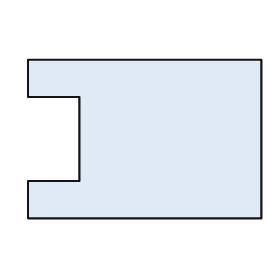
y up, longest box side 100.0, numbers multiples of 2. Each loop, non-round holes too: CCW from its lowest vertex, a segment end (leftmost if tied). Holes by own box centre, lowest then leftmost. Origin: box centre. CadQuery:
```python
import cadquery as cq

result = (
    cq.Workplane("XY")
    .moveTo(-50.0, -34.0)
    .lineTo(50.0, -34.0)
    .lineTo(50.0, 34.0)
    .lineTo(-50.0, 34.0)
    .lineTo(-50.0, 18.0)
    .lineTo(-28.0, 18.0)
    .lineTo(-28.0, -18.0)
    .lineTo(-50.0, -18.0)
    .close()
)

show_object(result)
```